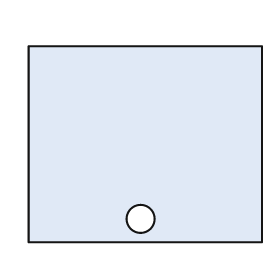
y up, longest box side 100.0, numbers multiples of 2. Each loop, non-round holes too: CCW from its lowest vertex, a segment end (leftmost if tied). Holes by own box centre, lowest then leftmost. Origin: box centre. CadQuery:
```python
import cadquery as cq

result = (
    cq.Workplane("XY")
    .moveTo(-50.0, -42.0)
    .lineTo(50.0, -42.0)
    .lineTo(50.0, 42.0)
    .lineTo(-50.0, 42.0)
    .close()
    .moveTo(-2.0, -32.0)
    .circle(6.0)
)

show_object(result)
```